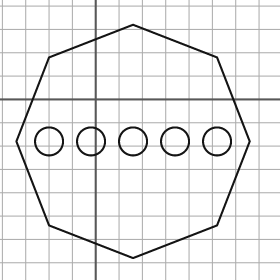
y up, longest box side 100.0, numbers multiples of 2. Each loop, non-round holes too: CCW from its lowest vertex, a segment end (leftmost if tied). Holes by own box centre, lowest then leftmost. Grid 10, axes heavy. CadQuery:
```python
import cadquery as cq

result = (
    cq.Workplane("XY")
    .moveTo(16.0, -68.0)
    .lineTo(52.0, -54.0)
    .lineTo(66.0, -18.0)
    .lineTo(52.0, 18.0)
    .lineTo(16.0, 32.0)
    .lineTo(-20.0, 18.0)
    .lineTo(-34.0, -18.0)
    .lineTo(-20.0, -54.0)
    .close()
    .moveTo(-20.0, -18.0)
    .circle(6.0)
    .moveTo(-2.0, -18.0)
    .circle(6.0)
    .moveTo(16.0, -18.0)
    .circle(6.0)
    .moveTo(34.0, -18.0)
    .circle(6.0)
    .moveTo(52.0, -18.0)
    .circle(6.0)
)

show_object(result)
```